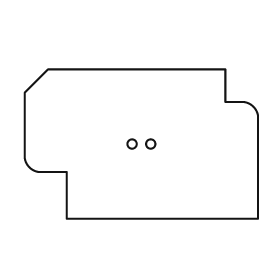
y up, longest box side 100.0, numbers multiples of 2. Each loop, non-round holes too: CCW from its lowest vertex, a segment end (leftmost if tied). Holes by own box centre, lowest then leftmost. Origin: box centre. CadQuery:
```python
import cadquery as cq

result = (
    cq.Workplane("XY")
    .moveTo(-32.0, -32.0)
    .lineTo(50.0, -32.0)
    .lineTo(50.0, 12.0)
    .threePointArc((48.0, 16.0), (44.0, 18.0))
    .lineTo(36.0, 18.0)
    .lineTo(36.0, 32.0)
    .lineTo(-40.0, 32.0)
    .lineTo(-50.0, 22.0)
    .lineTo(-50.0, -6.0)
    .threePointArc((-48.0, -10.0), (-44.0, -12.0))
    .lineTo(-32.0, -12.0)
    .close()
    .moveTo(-4.0, 0.0)
    .circle(2.0)
    .moveTo(4.0, 0.0)
    .circle(2.0)
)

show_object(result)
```